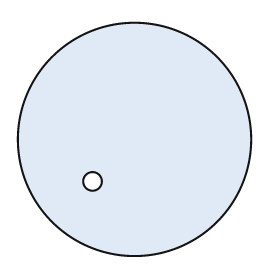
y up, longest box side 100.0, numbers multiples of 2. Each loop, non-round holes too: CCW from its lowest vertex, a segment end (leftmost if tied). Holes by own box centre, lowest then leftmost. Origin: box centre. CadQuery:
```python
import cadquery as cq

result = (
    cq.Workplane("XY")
    .moveTo(0.0, 0.0)
    .circle(50.0)
    .moveTo(-18.0, -18.0)
    .circle(4.0)
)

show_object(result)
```